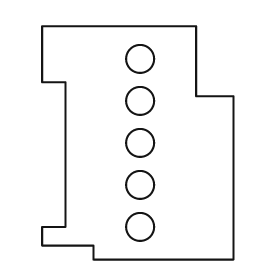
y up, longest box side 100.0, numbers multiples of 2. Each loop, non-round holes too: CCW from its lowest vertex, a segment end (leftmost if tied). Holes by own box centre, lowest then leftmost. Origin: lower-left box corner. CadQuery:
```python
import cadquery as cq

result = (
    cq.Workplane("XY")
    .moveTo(22.0, 0.0)
    .lineTo(82.0, 0.0)
    .lineTo(82.0, 70.0)
    .lineTo(66.0, 70.0)
    .lineTo(66.0, 100.0)
    .lineTo(0.0, 100.0)
    .lineTo(0.0, 76.0)
    .lineTo(10.0, 76.0)
    .lineTo(10.0, 14.0)
    .lineTo(0.0, 14.0)
    .lineTo(0.0, 6.0)
    .lineTo(22.0, 6.0)
    .close()
    .moveTo(42.0, 14.0)
    .circle(6.0)
    .moveTo(42.0, 32.0)
    .circle(6.0)
    .moveTo(42.0, 50.0)
    .circle(6.0)
    .moveTo(42.0, 68.0)
    .circle(6.0)
    .moveTo(42.0, 86.0)
    .circle(6.0)
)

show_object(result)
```